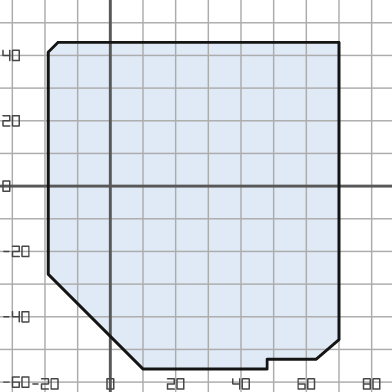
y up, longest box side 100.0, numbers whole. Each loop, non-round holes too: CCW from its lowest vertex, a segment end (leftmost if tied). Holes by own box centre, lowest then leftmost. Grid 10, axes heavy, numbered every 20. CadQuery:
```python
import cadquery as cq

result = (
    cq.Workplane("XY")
    .moveTo(10.0, -56.0)
    .lineTo(48.0, -56.0)
    .lineTo(48.0, -53.0)
    .lineTo(63.0, -53.0)
    .lineTo(70.0, -47.0)
    .lineTo(70.0, 44.0)
    .lineTo(-16.0, 44.0)
    .lineTo(-19.0, 41.0)
    .lineTo(-19.0, -27.0)
    .close()
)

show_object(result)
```